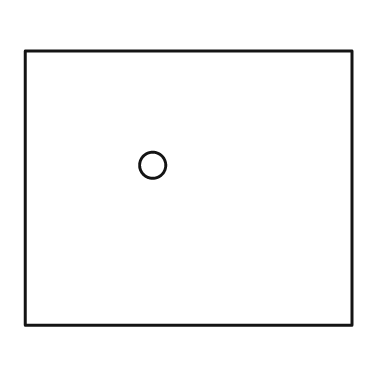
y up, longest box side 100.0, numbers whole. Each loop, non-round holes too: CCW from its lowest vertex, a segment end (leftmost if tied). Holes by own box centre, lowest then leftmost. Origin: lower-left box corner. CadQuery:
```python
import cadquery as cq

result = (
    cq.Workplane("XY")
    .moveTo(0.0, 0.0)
    .lineTo(100.0, 0.0)
    .lineTo(100.0, 84.0)
    .lineTo(0.0, 84.0)
    .close()
    .moveTo(39.0, 49.0)
    .circle(4.0)
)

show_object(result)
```